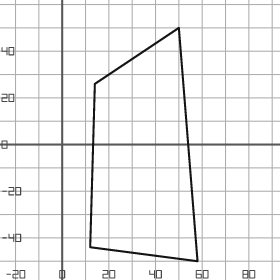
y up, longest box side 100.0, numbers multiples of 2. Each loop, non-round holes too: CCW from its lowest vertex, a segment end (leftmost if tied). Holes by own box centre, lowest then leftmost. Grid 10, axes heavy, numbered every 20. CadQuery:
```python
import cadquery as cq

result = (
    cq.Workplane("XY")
    .moveTo(58.0, -50.0)
    .lineTo(50.0, 50.0)
    .lineTo(14.0, 26.0)
    .lineTo(12.0, -44.0)
    .close()
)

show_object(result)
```